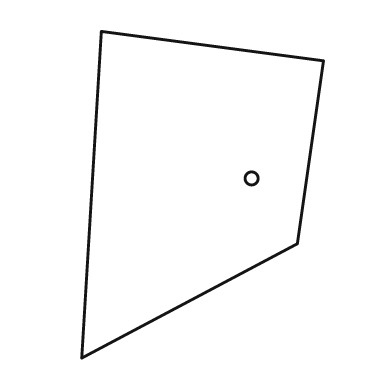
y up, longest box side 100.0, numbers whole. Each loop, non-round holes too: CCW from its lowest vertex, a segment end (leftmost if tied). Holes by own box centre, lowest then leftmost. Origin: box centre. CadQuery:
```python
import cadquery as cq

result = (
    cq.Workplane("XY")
    .moveTo(-37.0, -50.0)
    .lineTo(29.0, -15.0)
    .lineTo(37.0, 41.0)
    .lineTo(-31.0, 50.0)
    .close()
    .moveTo(15.0, 5.0)
    .circle(2.0)
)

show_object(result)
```